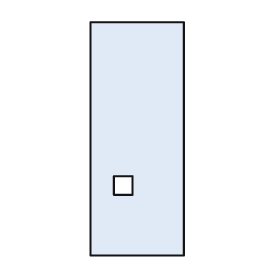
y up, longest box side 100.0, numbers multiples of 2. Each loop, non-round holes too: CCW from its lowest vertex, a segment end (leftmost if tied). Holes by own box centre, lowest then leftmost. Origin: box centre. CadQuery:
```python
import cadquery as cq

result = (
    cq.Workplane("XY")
    .moveTo(-20.0, -50.0)
    .lineTo(20.0, -50.0)
    .lineTo(20.0, 50.0)
    .lineTo(-20.0, 50.0)
    .close()
    .moveTo(-10.0, -24.0)
    .lineTo(-2.0, -24.0)
    .lineTo(-2.0, -16.0)
    .lineTo(-10.0, -16.0)
    .close()
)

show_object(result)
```